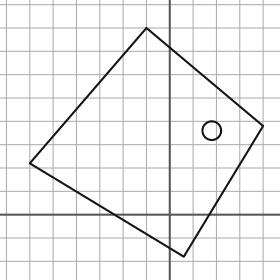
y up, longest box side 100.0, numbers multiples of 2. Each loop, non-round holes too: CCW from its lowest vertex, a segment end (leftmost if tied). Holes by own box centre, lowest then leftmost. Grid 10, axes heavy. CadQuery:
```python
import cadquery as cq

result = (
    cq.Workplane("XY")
    .moveTo(6.0, -18.0)
    .lineTo(40.0, 38.0)
    .lineTo(-10.0, 80.0)
    .lineTo(-60.0, 22.0)
    .close()
    .moveTo(18.0, 36.0)
    .circle(4.0)
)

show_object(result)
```